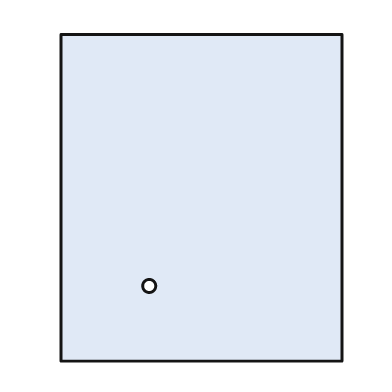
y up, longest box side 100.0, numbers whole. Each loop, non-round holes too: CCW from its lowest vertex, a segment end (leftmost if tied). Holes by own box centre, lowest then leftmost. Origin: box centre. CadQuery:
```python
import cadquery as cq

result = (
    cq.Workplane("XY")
    .moveTo(-43.0, -50.0)
    .lineTo(43.0, -50.0)
    .lineTo(43.0, 50.0)
    .lineTo(-43.0, 50.0)
    .close()
    .moveTo(-16.0, -27.0)
    .circle(2.0)
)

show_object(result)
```